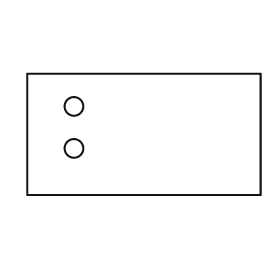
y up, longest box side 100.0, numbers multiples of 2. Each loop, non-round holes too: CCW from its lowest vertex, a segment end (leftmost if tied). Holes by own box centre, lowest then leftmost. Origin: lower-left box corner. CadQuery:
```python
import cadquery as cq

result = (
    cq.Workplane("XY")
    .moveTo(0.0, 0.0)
    .lineTo(100.0, 0.0)
    .lineTo(100.0, 52.0)
    .lineTo(0.0, 52.0)
    .close()
    .moveTo(20.0, 20.0)
    .circle(4.0)
    .moveTo(20.0, 38.0)
    .circle(4.0)
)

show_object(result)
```